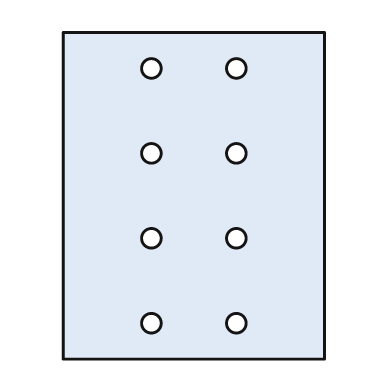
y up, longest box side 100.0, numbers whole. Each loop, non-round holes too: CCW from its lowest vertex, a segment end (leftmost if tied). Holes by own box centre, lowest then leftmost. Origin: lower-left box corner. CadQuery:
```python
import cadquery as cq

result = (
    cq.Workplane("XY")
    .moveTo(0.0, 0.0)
    .lineTo(80.0, 0.0)
    .lineTo(80.0, 100.0)
    .lineTo(0.0, 100.0)
    .close()
    .moveTo(27.0, 11.0)
    .circle(3.0)
    .moveTo(53.0, 11.0)
    .circle(3.0)
    .moveTo(27.0, 37.0)
    .circle(3.0)
    .moveTo(53.0, 37.0)
    .circle(3.0)
    .moveTo(27.0, 63.0)
    .circle(3.0)
    .moveTo(53.0, 63.0)
    .circle(3.0)
    .moveTo(27.0, 89.0)
    .circle(3.0)
    .moveTo(53.0, 89.0)
    .circle(3.0)
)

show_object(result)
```